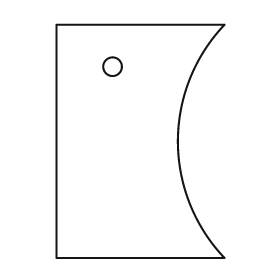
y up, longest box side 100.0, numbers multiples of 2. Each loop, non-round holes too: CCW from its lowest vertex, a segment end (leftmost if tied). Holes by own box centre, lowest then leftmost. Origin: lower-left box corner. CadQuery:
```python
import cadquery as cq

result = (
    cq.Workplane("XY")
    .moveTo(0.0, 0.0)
    .lineTo(72.0, 0.0)
    .threePointArc((52.0, 50.0), (72.0, 100.0))
    .lineTo(0.0, 100.0)
    .close()
    .moveTo(24.0, 82.0)
    .circle(4.0)
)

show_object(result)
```